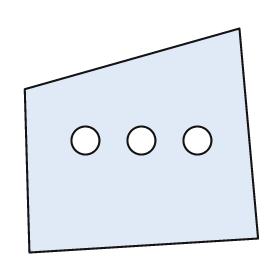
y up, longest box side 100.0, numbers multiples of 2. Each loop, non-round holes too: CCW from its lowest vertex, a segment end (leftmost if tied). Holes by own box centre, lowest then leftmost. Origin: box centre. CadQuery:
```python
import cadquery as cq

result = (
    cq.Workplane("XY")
    .moveTo(-48.0, -48.0)
    .lineTo(50.0, -42.0)
    .lineTo(42.0, 48.0)
    .lineTo(-50.0, 22.0)
    .close()
    .moveTo(-24.0, 0.0)
    .circle(6.0)
    .moveTo(0.0, 0.0)
    .circle(6.0)
    .moveTo(24.0, 0.0)
    .circle(6.0)
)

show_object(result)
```